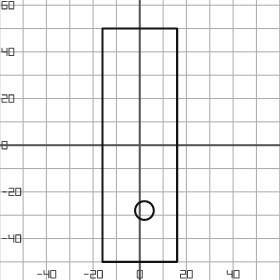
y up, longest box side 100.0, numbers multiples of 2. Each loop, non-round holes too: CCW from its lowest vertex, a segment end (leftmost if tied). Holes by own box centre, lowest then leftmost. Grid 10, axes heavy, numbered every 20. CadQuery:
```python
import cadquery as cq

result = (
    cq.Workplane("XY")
    .moveTo(-16.0, -50.0)
    .lineTo(16.0, -50.0)
    .lineTo(16.0, 50.0)
    .lineTo(-16.0, 50.0)
    .close()
    .moveTo(2.0, -28.0)
    .circle(4.0)
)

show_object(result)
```